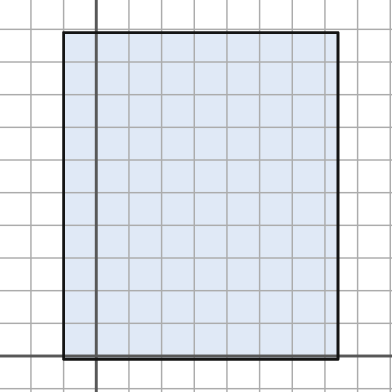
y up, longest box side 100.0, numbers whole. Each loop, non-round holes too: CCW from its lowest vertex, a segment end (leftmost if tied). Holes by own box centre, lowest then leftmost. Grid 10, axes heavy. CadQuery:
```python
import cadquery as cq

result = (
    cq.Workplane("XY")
    .moveTo(-10.0, -1.0)
    .lineTo(74.0, -1.0)
    .lineTo(74.0, 99.0)
    .lineTo(-10.0, 99.0)
    .close()
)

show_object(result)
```